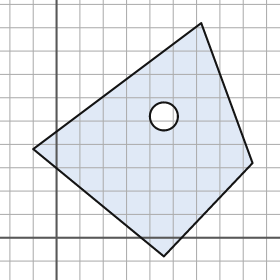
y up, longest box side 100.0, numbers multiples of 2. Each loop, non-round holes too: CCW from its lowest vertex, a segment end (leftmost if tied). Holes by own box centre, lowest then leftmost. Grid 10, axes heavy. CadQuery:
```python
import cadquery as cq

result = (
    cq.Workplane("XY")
    .moveTo(46.0, -8.0)
    .lineTo(84.0, 32.0)
    .lineTo(62.0, 92.0)
    .lineTo(-10.0, 38.0)
    .close()
    .moveTo(46.0, 52.0)
    .circle(6.0)
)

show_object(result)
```